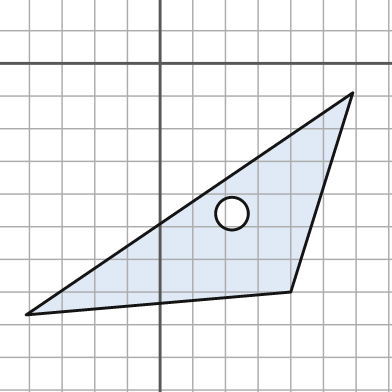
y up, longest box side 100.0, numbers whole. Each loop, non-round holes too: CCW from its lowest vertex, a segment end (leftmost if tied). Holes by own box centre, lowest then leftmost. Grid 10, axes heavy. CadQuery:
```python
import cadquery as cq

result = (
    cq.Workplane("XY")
    .moveTo(-41.0, -77.0)
    .lineTo(40.0, -70.0)
    .lineTo(59.0, -9.0)
    .close()
    .moveTo(22.0, -46.0)
    .circle(5.0)
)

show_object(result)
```